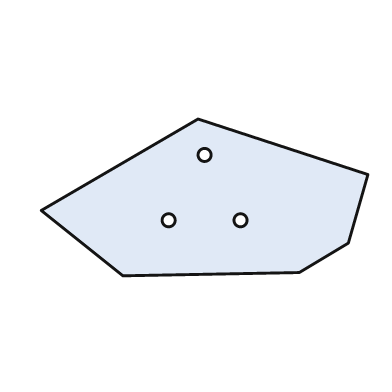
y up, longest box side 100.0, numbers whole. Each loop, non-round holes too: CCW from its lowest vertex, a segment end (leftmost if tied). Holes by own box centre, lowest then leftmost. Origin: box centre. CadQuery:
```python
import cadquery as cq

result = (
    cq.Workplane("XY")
    .moveTo(-25.0, -24.0)
    .lineTo(29.0, -23.0)
    .lineTo(44.0, -14.0)
    .lineTo(50.0, 7.0)
    .lineTo(-2.0, 24.0)
    .lineTo(-50.0, -4.0)
    .close()
    .moveTo(-11.0, -7.0)
    .circle(2.0)
    .moveTo(11.0, -7.0)
    .circle(2.0)
    .moveTo(0.0, 13.0)
    .circle(2.0)
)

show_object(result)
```